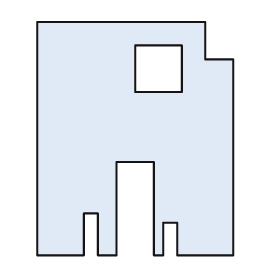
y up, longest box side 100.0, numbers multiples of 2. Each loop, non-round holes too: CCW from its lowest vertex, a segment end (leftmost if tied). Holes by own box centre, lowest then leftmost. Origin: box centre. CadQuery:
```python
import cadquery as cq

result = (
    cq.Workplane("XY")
    .moveTo(-42.0, -50.0)
    .lineTo(-22.0, -50.0)
    .lineTo(-22.0, -32.0)
    .lineTo(-16.0, -32.0)
    .lineTo(-16.0, -50.0)
    .lineTo(-8.0, -50.0)
    .lineTo(-8.0, -10.0)
    .lineTo(8.0, -10.0)
    .lineTo(8.0, -50.0)
    .lineTo(12.0, -50.0)
    .lineTo(12.0, -36.0)
    .lineTo(18.0, -36.0)
    .lineTo(18.0, -50.0)
    .lineTo(42.0, -50.0)
    .lineTo(42.0, 34.0)
    .lineTo(30.0, 34.0)
    .lineTo(30.0, 50.0)
    .lineTo(-42.0, 50.0)
    .close()
    .moveTo(0.0, 20.0)
    .lineTo(20.0, 20.0)
    .lineTo(20.0, 40.0)
    .lineTo(0.0, 40.0)
    .close()
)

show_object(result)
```